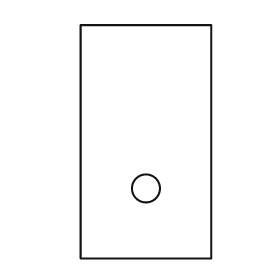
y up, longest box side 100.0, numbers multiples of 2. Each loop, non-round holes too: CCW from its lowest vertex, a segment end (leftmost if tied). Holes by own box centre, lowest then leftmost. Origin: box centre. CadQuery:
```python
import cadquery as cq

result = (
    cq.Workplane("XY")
    .moveTo(-28.0, -50.0)
    .lineTo(28.0, -50.0)
    .lineTo(28.0, 50.0)
    .lineTo(-28.0, 50.0)
    .close()
    .moveTo(0.0, -20.0)
    .circle(6.0)
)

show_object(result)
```